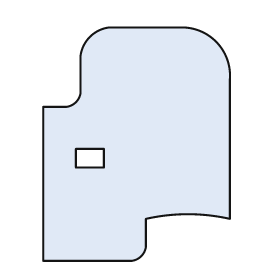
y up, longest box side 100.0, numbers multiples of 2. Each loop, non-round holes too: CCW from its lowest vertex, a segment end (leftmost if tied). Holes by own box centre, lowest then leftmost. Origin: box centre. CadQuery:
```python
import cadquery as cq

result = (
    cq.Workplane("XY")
    .moveTo(-40.0, -50.0)
    .lineTo(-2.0, -50.0)
    .threePointArc((2.0, -48.0), (4.0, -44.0))
    .lineTo(4.0, -32.0)
    .threePointArc((22.0, -30.0), (40.0, -32.0))
    .lineTo(40.0, 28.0)
    .threePointArc((34.0, 44.0), (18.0, 50.0))
    .lineTo(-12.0, 50.0)
    .threePointArc((-20.0, 46.0), (-24.0, 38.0))
    .lineTo(-24.0, 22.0)
    .threePointArc((-26.0, 18.0), (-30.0, 16.0))
    .lineTo(-40.0, 16.0)
    .close()
    .moveTo(-26.0, -10.0)
    .lineTo(-14.0, -10.0)
    .lineTo(-14.0, -2.0)
    .lineTo(-26.0, -2.0)
    .close()
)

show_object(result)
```